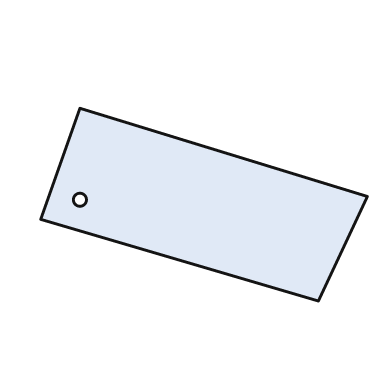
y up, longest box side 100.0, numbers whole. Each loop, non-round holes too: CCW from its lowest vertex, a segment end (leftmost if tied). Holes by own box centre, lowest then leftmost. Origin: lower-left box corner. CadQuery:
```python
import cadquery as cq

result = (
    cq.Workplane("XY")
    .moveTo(85.0, 0.0)
    .lineTo(100.0, 32.0)
    .lineTo(12.0, 59.0)
    .lineTo(0.0, 25.0)
    .close()
    .moveTo(12.0, 31.0)
    .circle(2.0)
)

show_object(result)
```